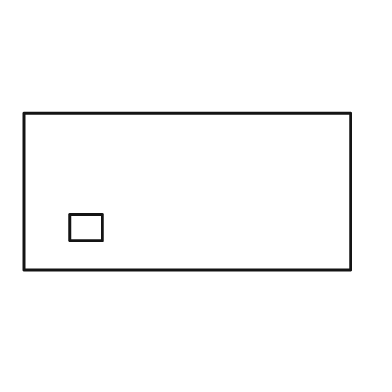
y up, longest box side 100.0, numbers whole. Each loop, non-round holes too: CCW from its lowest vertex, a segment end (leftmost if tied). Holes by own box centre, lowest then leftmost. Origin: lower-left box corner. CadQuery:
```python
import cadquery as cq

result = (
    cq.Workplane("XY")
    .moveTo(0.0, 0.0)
    .lineTo(100.0, 0.0)
    .lineTo(100.0, 48.0)
    .lineTo(0.0, 48.0)
    .close()
    .moveTo(14.0, 9.0)
    .lineTo(24.0, 9.0)
    .lineTo(24.0, 17.0)
    .lineTo(14.0, 17.0)
    .close()
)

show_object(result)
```